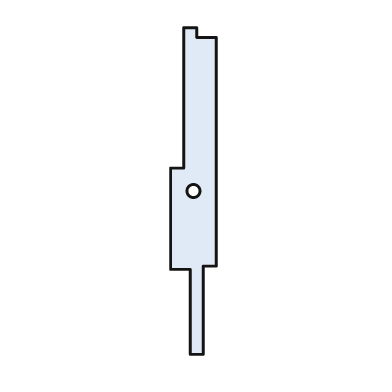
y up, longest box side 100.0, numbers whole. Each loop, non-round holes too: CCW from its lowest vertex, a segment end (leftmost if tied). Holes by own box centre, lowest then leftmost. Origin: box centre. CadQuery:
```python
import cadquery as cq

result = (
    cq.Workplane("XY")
    .moveTo(-1.0, -50.0)
    .lineTo(3.0, -50.0)
    .lineTo(3.0, -23.0)
    .lineTo(7.0, -23.0)
    .lineTo(7.0, 47.0)
    .lineTo(1.0, 47.0)
    .lineTo(1.0, 50.0)
    .lineTo(-3.0, 50.0)
    .lineTo(-3.0, 7.0)
    .lineTo(-7.0, 7.0)
    .lineTo(-7.0, -24.0)
    .lineTo(-1.0, -24.0)
    .close()
    .moveTo(0.0, 0.0)
    .circle(2.0)
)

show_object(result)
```